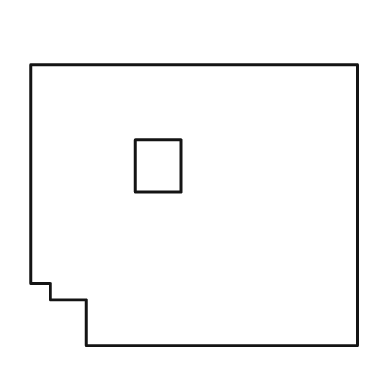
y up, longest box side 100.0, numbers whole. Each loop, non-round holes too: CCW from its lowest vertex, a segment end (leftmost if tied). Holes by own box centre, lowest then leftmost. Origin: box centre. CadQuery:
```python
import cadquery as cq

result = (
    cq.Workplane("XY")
    .moveTo(-33.0, -43.0)
    .lineTo(50.0, -43.0)
    .lineTo(50.0, 43.0)
    .lineTo(-50.0, 43.0)
    .lineTo(-50.0, -24.0)
    .lineTo(-44.0, -24.0)
    .lineTo(-44.0, -29.0)
    .lineTo(-33.0, -29.0)
    .close()
    .moveTo(-18.0, 4.0)
    .lineTo(-4.0, 4.0)
    .lineTo(-4.0, 20.0)
    .lineTo(-18.0, 20.0)
    .close()
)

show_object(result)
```